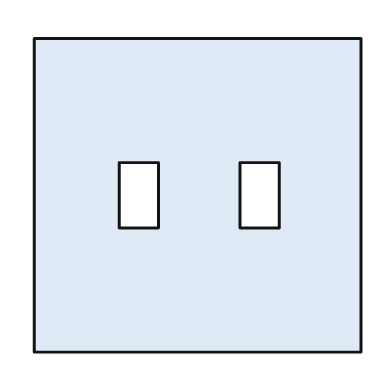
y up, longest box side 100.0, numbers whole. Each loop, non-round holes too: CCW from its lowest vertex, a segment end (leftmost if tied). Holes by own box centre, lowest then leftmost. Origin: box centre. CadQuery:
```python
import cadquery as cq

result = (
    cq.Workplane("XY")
    .moveTo(-50.0, -48.0)
    .lineTo(50.0, -48.0)
    .lineTo(50.0, 48.0)
    .lineTo(-50.0, 48.0)
    .close()
    .moveTo(-24.0, -10.0)
    .lineTo(-12.0, -10.0)
    .lineTo(-12.0, 10.0)
    .lineTo(-24.0, 10.0)
    .close()
    .moveTo(13.0, -10.0)
    .lineTo(25.0, -10.0)
    .lineTo(25.0, 10.0)
    .lineTo(13.0, 10.0)
    .close()
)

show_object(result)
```